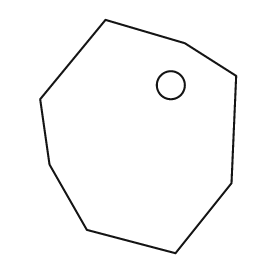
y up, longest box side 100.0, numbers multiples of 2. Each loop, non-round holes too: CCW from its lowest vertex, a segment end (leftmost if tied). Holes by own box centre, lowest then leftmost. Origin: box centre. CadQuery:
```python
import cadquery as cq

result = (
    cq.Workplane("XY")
    .moveTo(16.0, -50.0)
    .lineTo(40.0, -20.0)
    .lineTo(42.0, 26.0)
    .lineTo(20.0, 40.0)
    .lineTo(-14.0, 50.0)
    .lineTo(-42.0, 16.0)
    .lineTo(-38.0, -12.0)
    .lineTo(-22.0, -40.0)
    .close()
    .moveTo(14.0, 22.0)
    .circle(6.0)
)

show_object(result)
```